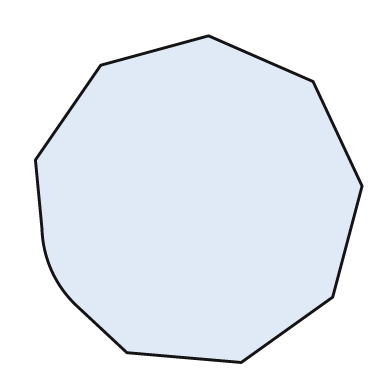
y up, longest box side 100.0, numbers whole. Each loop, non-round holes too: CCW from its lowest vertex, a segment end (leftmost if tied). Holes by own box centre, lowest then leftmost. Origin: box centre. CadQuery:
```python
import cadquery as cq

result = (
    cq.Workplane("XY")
    .moveTo(13.0, -50.0)
    .lineTo(41.0, -30.0)
    .lineTo(50.0, 4.0)
    .lineTo(35.0, 36.0)
    .lineTo(3.0, 50.0)
    .lineTo(-30.0, 41.0)
    .lineTo(-50.0, 12.0)
    .lineTo(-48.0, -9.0)
    .threePointArc((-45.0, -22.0), (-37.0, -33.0))
    .lineTo(-22.0, -47.0)
    .close()
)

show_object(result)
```